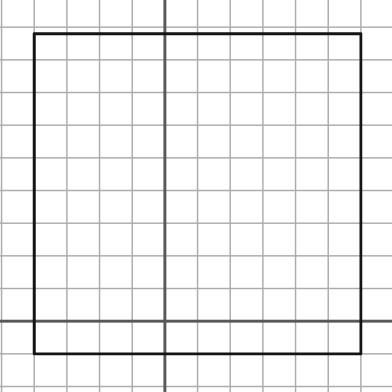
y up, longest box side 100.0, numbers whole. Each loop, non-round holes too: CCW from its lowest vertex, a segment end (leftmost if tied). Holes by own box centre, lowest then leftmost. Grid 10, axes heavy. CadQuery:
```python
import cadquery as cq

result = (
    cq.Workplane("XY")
    .moveTo(-40.0, -10.0)
    .lineTo(60.0, -10.0)
    .lineTo(60.0, 88.0)
    .lineTo(-40.0, 88.0)
    .close()
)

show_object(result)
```